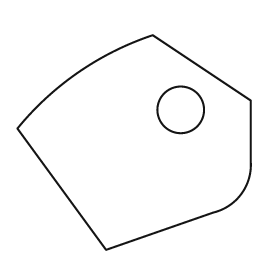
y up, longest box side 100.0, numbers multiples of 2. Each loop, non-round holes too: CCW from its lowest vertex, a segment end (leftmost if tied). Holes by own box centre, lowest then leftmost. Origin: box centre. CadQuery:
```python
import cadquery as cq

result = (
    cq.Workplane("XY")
    .moveTo(-12.0, -46.0)
    .lineTo(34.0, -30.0)
    .threePointArc((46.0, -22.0), (50.0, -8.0))
    .lineTo(50.0, 18.0)
    .lineTo(8.0, 46.0)
    .threePointArc((-24.0, 30.0), (-50.0, 6.0))
    .close()
    .moveTo(20.0, 14.0)
    .circle(10.0)
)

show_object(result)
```